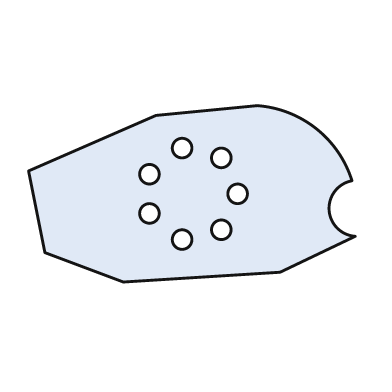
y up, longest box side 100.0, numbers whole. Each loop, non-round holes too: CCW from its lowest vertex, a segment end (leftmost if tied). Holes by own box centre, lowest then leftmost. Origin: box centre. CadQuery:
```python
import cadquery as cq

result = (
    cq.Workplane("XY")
    .moveTo(-21.0, -27.0)
    .lineTo(27.0, -24.0)
    .lineTo(50.0, -13.0)
    .threePointArc((42.0, -5.0), (49.0, 4.0))
    .threePointArc((38.0, 20.0), (20.0, 27.0))
    .lineTo(-11.0, 24.0)
    .lineTo(-50.0, 7.0)
    .lineTo(-45.0, -18.0)
    .close()
    .moveTo(-3.0, -14.0)
    .circle(3.0)
    .moveTo(9.0, -11.0)
    .circle(3.0)
    .moveTo(-13.0, -6.0)
    .circle(3.0)
    .moveTo(14.0, 0.0)
    .circle(3.0)
    .moveTo(-13.0, 6.0)
    .circle(3.0)
    .moveTo(9.0, 11.0)
    .circle(3.0)
    .moveTo(-3.0, 14.0)
    .circle(3.0)
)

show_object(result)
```